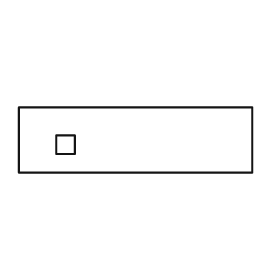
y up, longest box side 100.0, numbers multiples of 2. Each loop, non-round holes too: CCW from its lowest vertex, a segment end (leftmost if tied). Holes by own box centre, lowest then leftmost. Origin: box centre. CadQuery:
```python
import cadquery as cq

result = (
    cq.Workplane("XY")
    .moveTo(-50.0, -14.0)
    .lineTo(50.0, -14.0)
    .lineTo(50.0, 14.0)
    .lineTo(-50.0, 14.0)
    .close()
    .moveTo(-34.0, -6.0)
    .lineTo(-26.0, -6.0)
    .lineTo(-26.0, 2.0)
    .lineTo(-34.0, 2.0)
    .close()
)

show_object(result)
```